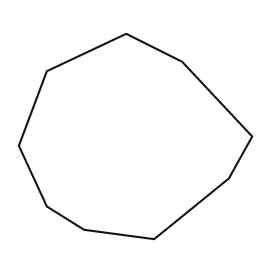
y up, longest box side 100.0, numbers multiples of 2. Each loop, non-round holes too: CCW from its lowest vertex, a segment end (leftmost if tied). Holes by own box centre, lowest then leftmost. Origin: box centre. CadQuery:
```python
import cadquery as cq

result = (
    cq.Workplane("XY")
    .moveTo(8.0, -44.0)
    .lineTo(40.0, -18.0)
    .lineTo(50.0, 0.0)
    .lineTo(20.0, 32.0)
    .lineTo(-4.0, 44.0)
    .lineTo(-38.0, 28.0)
    .lineTo(-50.0, -4.0)
    .lineTo(-38.0, -30.0)
    .lineTo(-22.0, -40.0)
    .close()
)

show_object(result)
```